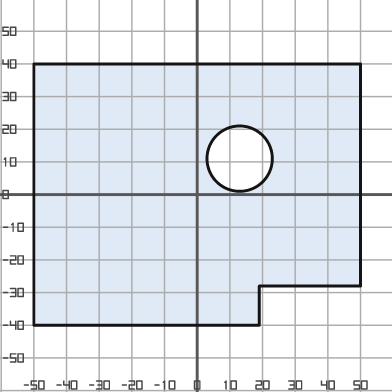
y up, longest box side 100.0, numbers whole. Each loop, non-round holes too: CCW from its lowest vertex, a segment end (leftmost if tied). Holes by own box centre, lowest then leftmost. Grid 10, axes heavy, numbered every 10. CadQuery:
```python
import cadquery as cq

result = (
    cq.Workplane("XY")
    .moveTo(-50.0, -40.0)
    .lineTo(19.0, -40.0)
    .lineTo(19.0, -28.0)
    .lineTo(50.0, -28.0)
    .lineTo(50.0, 40.0)
    .lineTo(-50.0, 40.0)
    .close()
    .moveTo(13.0, 11.0)
    .circle(10.0)
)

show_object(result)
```